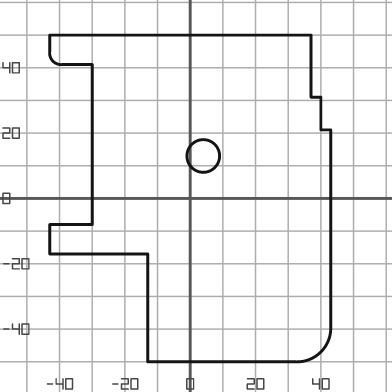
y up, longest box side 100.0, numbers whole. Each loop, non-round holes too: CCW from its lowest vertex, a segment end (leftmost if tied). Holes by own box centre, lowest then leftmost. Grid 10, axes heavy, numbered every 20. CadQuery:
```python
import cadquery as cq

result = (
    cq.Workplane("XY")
    .moveTo(-13.0, -50.0)
    .lineTo(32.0, -50.0)
    .threePointArc((40.0, -47.0), (43.0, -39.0))
    .lineTo(43.0, 21.0)
    .lineTo(40.0, 21.0)
    .lineTo(40.0, 31.0)
    .lineTo(37.0, 31.0)
    .lineTo(37.0, 50.0)
    .lineTo(-43.0, 50.0)
    .lineTo(-43.0, 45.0)
    .threePointArc((-42.0, 42.0), (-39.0, 41.0))
    .lineTo(-30.0, 41.0)
    .lineTo(-30.0, -8.0)
    .lineTo(-43.0, -8.0)
    .lineTo(-43.0, -17.0)
    .lineTo(-13.0, -17.0)
    .close()
    .moveTo(4.0, 13.0)
    .circle(5.0)
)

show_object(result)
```